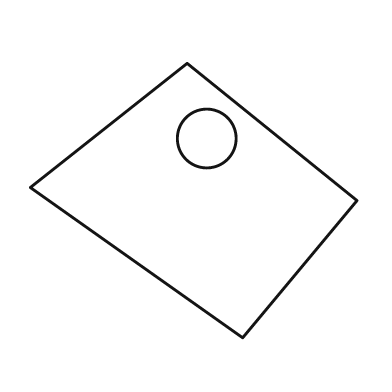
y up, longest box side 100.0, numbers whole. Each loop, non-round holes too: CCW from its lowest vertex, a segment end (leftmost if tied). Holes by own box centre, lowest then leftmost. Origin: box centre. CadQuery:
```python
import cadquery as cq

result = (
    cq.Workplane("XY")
    .moveTo(15.0, -42.0)
    .lineTo(50.0, 0.0)
    .lineTo(-2.0, 42.0)
    .lineTo(-50.0, 4.0)
    .close()
    .moveTo(4.0, 19.0)
    .circle(9.0)
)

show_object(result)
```